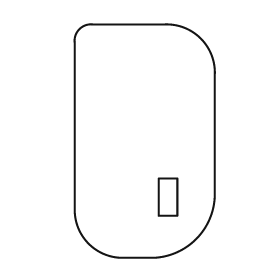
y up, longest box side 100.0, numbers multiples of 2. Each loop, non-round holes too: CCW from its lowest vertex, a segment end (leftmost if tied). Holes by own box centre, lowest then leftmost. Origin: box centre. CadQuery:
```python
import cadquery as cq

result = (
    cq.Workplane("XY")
    .moveTo(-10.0, -50.0)
    .lineTo(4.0, -50.0)
    .threePointArc((22.0, -42.0), (30.0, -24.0))
    .lineTo(30.0, 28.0)
    .threePointArc((24.0, 44.0), (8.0, 50.0))
    .lineTo(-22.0, 50.0)
    .threePointArc((-28.0, 48.0), (-30.0, 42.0))
    .lineTo(-30.0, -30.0)
    .threePointArc((-24.0, -44.0), (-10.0, -50.0))
    .close()
    .moveTo(6.0, -32.0)
    .lineTo(14.0, -32.0)
    .lineTo(14.0, -16.0)
    .lineTo(6.0, -16.0)
    .close()
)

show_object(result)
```